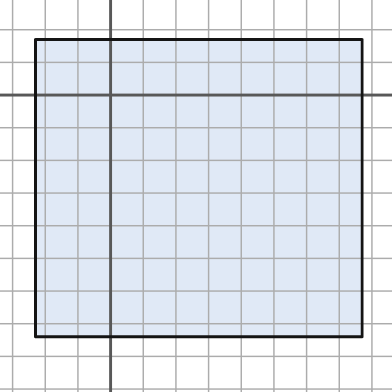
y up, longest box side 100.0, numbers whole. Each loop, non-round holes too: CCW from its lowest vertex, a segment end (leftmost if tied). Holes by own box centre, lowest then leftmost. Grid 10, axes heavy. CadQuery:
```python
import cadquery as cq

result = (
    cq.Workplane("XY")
    .moveTo(-23.0, -74.0)
    .lineTo(77.0, -74.0)
    .lineTo(77.0, 17.0)
    .lineTo(-23.0, 17.0)
    .close()
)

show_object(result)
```